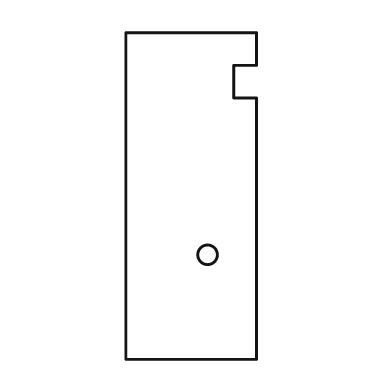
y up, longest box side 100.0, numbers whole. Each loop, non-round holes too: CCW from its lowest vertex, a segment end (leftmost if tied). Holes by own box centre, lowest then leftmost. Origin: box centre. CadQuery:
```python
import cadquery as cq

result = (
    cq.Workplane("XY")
    .moveTo(-20.0, -50.0)
    .lineTo(20.0, -50.0)
    .lineTo(20.0, 30.0)
    .lineTo(13.0, 30.0)
    .lineTo(13.0, 40.0)
    .lineTo(20.0, 40.0)
    .lineTo(20.0, 50.0)
    .lineTo(-20.0, 50.0)
    .close()
    .moveTo(5.0, -18.0)
    .circle(3.0)
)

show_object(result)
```